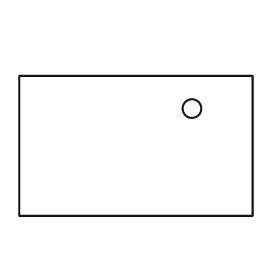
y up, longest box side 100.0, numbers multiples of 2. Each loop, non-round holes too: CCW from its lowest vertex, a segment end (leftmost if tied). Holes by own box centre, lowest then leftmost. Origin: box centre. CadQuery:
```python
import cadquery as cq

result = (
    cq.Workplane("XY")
    .moveTo(-50.0, -30.0)
    .lineTo(50.0, -30.0)
    .lineTo(50.0, 30.0)
    .lineTo(-50.0, 30.0)
    .close()
    .moveTo(24.0, 16.0)
    .circle(4.0)
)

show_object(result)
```